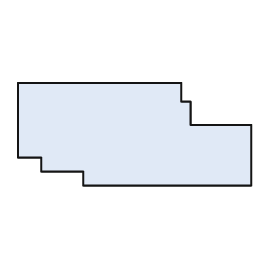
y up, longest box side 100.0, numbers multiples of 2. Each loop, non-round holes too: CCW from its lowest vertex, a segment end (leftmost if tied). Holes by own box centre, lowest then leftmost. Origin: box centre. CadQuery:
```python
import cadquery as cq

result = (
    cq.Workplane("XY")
    .moveTo(-22.0, -22.0)
    .lineTo(50.0, -22.0)
    .lineTo(50.0, 4.0)
    .lineTo(24.0, 4.0)
    .lineTo(24.0, 14.0)
    .lineTo(20.0, 14.0)
    .lineTo(20.0, 22.0)
    .lineTo(-50.0, 22.0)
    .lineTo(-50.0, -10.0)
    .lineTo(-40.0, -10.0)
    .lineTo(-40.0, -16.0)
    .lineTo(-22.0, -16.0)
    .close()
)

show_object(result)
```